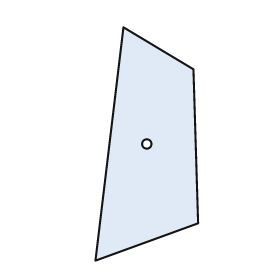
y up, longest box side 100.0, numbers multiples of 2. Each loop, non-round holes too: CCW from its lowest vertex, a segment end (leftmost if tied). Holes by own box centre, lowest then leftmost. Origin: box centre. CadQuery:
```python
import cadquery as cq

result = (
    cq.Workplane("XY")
    .moveTo(-22.0, -50.0)
    .lineTo(22.0, -34.0)
    .lineTo(20.0, 32.0)
    .lineTo(-10.0, 50.0)
    .close()
    .moveTo(0.0, 0.0)
    .circle(2.0)
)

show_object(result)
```